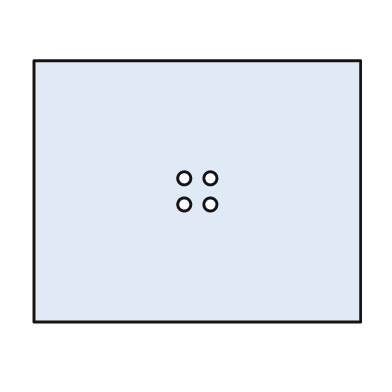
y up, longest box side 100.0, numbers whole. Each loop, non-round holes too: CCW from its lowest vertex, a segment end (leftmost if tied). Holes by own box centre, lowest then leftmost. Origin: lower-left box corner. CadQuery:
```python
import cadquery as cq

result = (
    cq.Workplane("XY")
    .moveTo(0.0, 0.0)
    .lineTo(100.0, 0.0)
    .lineTo(100.0, 80.0)
    .lineTo(0.0, 80.0)
    .close()
    .moveTo(46.0, 36.0)
    .circle(2.0)
    .moveTo(54.0, 36.0)
    .circle(2.0)
    .moveTo(46.0, 44.0)
    .circle(2.0)
    .moveTo(54.0, 44.0)
    .circle(2.0)
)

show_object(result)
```